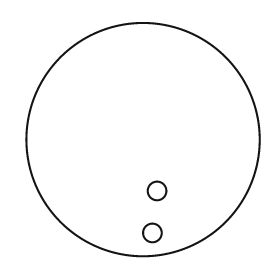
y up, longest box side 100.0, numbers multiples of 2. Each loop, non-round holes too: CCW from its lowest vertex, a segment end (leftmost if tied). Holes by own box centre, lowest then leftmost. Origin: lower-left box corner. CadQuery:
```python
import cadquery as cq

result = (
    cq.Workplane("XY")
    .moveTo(50.0, 50.0)
    .circle(50.0)
    .moveTo(54.0, 10.0)
    .circle(4.0)
    .moveTo(56.0, 28.0)
    .circle(4.0)
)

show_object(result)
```